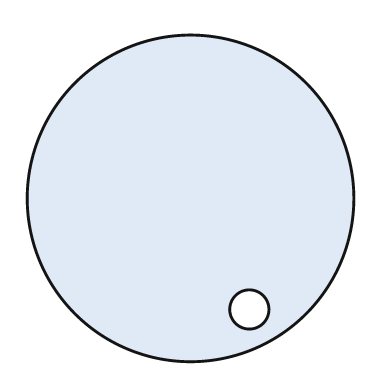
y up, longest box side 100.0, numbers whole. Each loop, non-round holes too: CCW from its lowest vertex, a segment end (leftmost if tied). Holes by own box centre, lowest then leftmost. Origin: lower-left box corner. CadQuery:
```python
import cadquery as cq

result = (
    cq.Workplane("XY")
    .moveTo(50.0, 50.0)
    .circle(50.0)
    .moveTo(68.0, 16.0)
    .circle(6.0)
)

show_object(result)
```